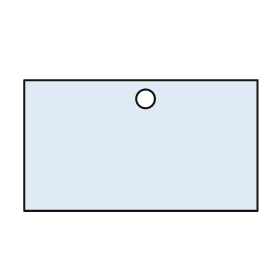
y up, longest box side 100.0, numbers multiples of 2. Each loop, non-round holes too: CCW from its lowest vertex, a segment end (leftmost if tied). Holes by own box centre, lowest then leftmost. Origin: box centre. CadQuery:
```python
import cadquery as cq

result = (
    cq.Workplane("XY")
    .moveTo(-50.0, -28.0)
    .lineTo(50.0, -28.0)
    .lineTo(50.0, 28.0)
    .lineTo(-50.0, 28.0)
    .close()
    .moveTo(2.0, 20.0)
    .circle(4.0)
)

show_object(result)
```